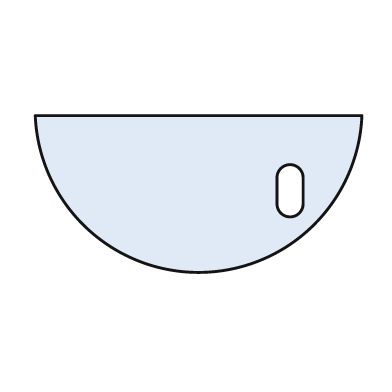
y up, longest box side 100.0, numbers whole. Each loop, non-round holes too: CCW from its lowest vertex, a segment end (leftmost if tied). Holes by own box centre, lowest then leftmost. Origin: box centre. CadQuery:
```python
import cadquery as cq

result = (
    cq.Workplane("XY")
    .moveTo(-50.0, 24.0)
    .threePointArc((0.0, -24.0), (50.0, 24.0))
    .close()
    .moveTo(24.0, -3.0)
    .threePointArc((28.0, -7.0), (32.0, -3.0))
    .lineTo(32.0, 5.0)
    .threePointArc((28.0, 9.0), (24.0, 5.0))
    .close()
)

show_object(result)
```